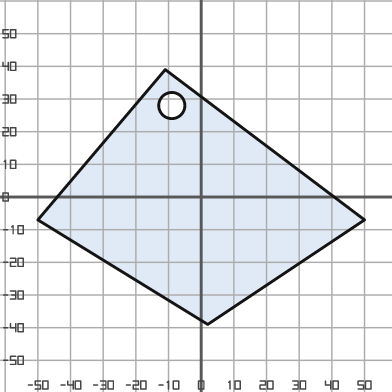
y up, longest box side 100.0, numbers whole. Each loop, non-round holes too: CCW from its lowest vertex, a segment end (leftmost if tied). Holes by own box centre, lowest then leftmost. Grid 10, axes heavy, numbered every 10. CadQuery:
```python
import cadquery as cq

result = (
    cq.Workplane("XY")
    .moveTo(2.0, -39.0)
    .lineTo(50.0, -7.0)
    .lineTo(-11.0, 39.0)
    .lineTo(-50.0, -7.0)
    .close()
    .moveTo(-9.0, 28.0)
    .circle(4.0)
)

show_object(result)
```